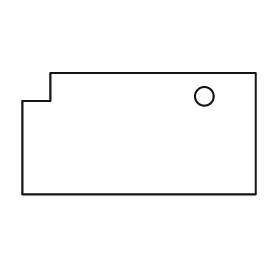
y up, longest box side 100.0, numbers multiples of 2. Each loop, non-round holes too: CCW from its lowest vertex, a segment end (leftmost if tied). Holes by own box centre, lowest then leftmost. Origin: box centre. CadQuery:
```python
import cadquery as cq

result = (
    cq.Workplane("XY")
    .moveTo(-50.0, -26.0)
    .lineTo(50.0, -26.0)
    .lineTo(50.0, 26.0)
    .lineTo(-38.0, 26.0)
    .lineTo(-38.0, 14.0)
    .lineTo(-50.0, 14.0)
    .close()
    .moveTo(28.0, 16.0)
    .circle(4.0)
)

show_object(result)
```